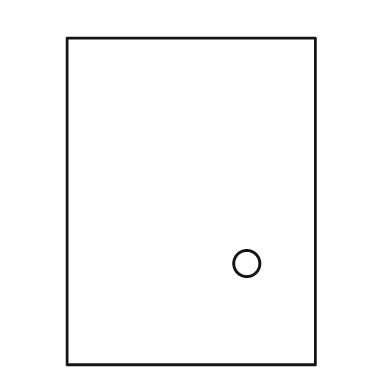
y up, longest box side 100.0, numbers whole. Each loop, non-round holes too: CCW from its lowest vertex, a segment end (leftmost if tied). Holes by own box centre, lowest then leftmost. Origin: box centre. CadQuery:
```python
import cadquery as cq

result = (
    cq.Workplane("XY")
    .moveTo(-38.0, -50.0)
    .lineTo(38.0, -50.0)
    .lineTo(38.0, 50.0)
    .lineTo(-38.0, 50.0)
    .close()
    .moveTo(17.0, -19.0)
    .circle(4.0)
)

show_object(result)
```